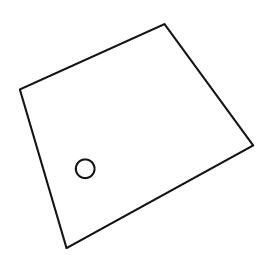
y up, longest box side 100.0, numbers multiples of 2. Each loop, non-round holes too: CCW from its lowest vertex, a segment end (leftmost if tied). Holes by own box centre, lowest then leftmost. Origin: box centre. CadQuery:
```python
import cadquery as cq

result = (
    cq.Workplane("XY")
    .moveTo(-30.0, -48.0)
    .lineTo(50.0, -4.0)
    .lineTo(12.0, 48.0)
    .lineTo(-50.0, 20.0)
    .close()
    .moveTo(-22.0, -14.0)
    .circle(4.0)
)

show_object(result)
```